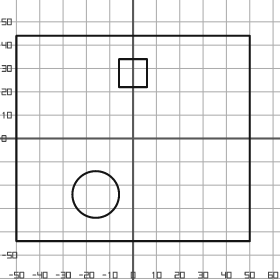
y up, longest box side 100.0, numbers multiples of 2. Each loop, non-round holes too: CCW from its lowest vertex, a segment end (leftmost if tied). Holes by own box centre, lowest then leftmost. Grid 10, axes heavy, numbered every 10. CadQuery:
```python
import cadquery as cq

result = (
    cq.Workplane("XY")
    .moveTo(-50.0, -44.0)
    .lineTo(50.0, -44.0)
    .lineTo(50.0, 44.0)
    .lineTo(-50.0, 44.0)
    .close()
    .moveTo(-16.0, -24.0)
    .circle(10.0)
    .moveTo(-6.0, 22.0)
    .lineTo(6.0, 22.0)
    .lineTo(6.0, 34.0)
    .lineTo(-6.0, 34.0)
    .close()
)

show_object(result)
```